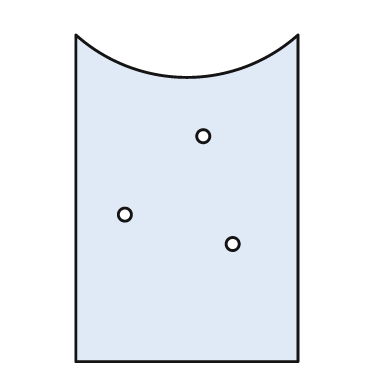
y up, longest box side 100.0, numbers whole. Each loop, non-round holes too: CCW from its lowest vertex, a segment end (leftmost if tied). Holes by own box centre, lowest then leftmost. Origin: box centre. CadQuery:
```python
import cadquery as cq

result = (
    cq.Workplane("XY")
    .moveTo(-34.0, -50.0)
    .lineTo(34.0, -50.0)
    .lineTo(34.0, 50.0)
    .threePointArc((0.0, 37.0), (-34.0, 50.0))
    .close()
    .moveTo(14.0, -14.0)
    .circle(2.0)
    .moveTo(-19.0, -5.0)
    .circle(2.0)
    .moveTo(5.0, 19.0)
    .circle(2.0)
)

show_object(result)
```